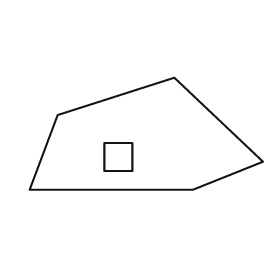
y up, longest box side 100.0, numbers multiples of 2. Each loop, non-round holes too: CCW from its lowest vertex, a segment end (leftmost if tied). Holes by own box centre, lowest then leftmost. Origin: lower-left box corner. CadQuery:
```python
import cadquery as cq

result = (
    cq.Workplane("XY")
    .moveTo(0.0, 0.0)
    .lineTo(70.0, 0.0)
    .lineTo(100.0, 12.0)
    .lineTo(62.0, 48.0)
    .lineTo(12.0, 32.0)
    .close()
    .moveTo(32.0, 8.0)
    .lineTo(44.0, 8.0)
    .lineTo(44.0, 20.0)
    .lineTo(32.0, 20.0)
    .close()
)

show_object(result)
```